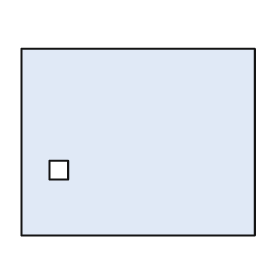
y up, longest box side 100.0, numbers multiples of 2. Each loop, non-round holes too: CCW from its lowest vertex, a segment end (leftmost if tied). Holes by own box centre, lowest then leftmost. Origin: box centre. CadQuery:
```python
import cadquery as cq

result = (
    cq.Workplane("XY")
    .moveTo(-50.0, -40.0)
    .lineTo(50.0, -40.0)
    .lineTo(50.0, 40.0)
    .lineTo(-50.0, 40.0)
    .close()
    .moveTo(-38.0, -16.0)
    .lineTo(-30.0, -16.0)
    .lineTo(-30.0, -8.0)
    .lineTo(-38.0, -8.0)
    .close()
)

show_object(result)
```